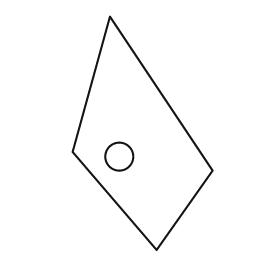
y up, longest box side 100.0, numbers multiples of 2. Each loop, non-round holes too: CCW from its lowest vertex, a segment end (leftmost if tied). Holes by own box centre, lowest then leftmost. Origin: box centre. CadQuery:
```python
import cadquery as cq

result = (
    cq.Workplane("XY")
    .moveTo(6.0, -50.0)
    .lineTo(30.0, -16.0)
    .lineTo(-14.0, 50.0)
    .lineTo(-30.0, -8.0)
    .close()
    .moveTo(-10.0, -10.0)
    .circle(6.0)
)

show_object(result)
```